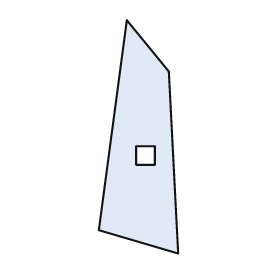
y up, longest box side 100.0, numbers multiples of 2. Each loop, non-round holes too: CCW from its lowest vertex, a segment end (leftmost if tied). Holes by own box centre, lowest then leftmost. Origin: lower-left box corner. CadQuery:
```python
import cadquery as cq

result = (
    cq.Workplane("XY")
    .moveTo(34.0, 0.0)
    .lineTo(30.0, 78.0)
    .lineTo(12.0, 100.0)
    .lineTo(0.0, 10.0)
    .close()
    .moveTo(16.0, 38.0)
    .lineTo(24.0, 38.0)
    .lineTo(24.0, 46.0)
    .lineTo(16.0, 46.0)
    .close()
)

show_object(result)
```